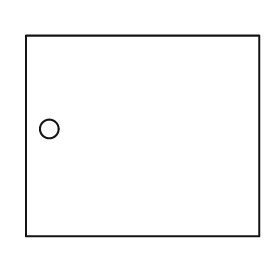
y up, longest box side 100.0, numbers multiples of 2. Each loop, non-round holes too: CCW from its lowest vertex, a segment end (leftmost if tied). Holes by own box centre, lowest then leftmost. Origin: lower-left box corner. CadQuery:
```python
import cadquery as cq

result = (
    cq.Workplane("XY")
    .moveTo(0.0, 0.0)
    .lineTo(100.0, 0.0)
    .lineTo(100.0, 86.0)
    .lineTo(0.0, 86.0)
    .close()
    .moveTo(10.0, 46.0)
    .circle(4.0)
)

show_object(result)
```